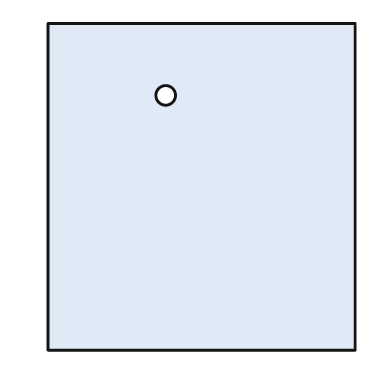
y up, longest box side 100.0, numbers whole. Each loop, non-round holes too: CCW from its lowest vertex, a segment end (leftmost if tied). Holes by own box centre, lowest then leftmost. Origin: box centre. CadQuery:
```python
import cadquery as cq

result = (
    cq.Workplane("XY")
    .moveTo(-47.0, -50.0)
    .lineTo(47.0, -50.0)
    .lineTo(47.0, 50.0)
    .lineTo(-47.0, 50.0)
    .close()
    .moveTo(-11.0, 28.0)
    .circle(3.0)
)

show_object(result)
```